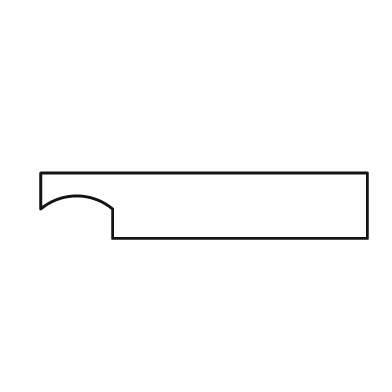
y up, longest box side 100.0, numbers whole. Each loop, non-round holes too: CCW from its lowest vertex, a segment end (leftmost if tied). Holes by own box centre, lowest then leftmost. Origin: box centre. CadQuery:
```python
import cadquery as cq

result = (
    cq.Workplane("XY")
    .moveTo(-28.0, -10.0)
    .lineTo(50.0, -10.0)
    .lineTo(50.0, 10.0)
    .lineTo(-50.0, 10.0)
    .lineTo(-50.0, -1.0)
    .threePointArc((-39.0, 3.0), (-28.0, -1.0))
    .close()
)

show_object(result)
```